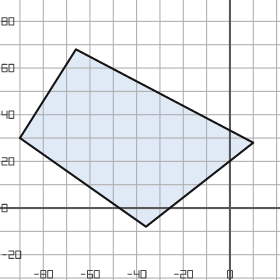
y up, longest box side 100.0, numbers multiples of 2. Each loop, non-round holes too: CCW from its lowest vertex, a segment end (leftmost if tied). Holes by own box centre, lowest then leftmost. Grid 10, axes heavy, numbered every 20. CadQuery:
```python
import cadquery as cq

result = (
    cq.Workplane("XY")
    .moveTo(-36.0, -8.0)
    .lineTo(10.0, 28.0)
    .lineTo(-66.0, 68.0)
    .lineTo(-90.0, 30.0)
    .close()
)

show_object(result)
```